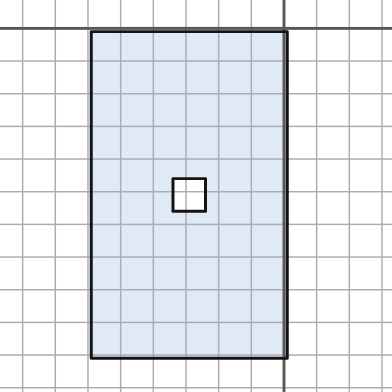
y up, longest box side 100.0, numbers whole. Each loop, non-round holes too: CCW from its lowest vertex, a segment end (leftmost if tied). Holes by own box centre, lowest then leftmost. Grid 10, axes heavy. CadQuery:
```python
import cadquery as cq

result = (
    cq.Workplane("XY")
    .moveTo(-59.0, -101.0)
    .lineTo(1.0, -101.0)
    .lineTo(1.0, -1.0)
    .lineTo(-59.0, -1.0)
    .close()
    .moveTo(-34.0, -56.0)
    .lineTo(-24.0, -56.0)
    .lineTo(-24.0, -46.0)
    .lineTo(-34.0, -46.0)
    .close()
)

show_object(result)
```